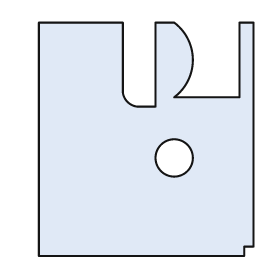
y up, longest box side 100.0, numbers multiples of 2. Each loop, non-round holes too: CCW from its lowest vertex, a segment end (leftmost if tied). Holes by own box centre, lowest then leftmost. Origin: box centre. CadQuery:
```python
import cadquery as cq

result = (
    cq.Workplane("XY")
    .moveTo(-46.0, -50.0)
    .lineTo(42.0, -50.0)
    .lineTo(42.0, -46.0)
    .lineTo(46.0, -46.0)
    .lineTo(46.0, 50.0)
    .lineTo(40.0, 50.0)
    .lineTo(40.0, 18.0)
    .lineTo(12.0, 18.0)
    .threePointArc((20.0, 34.0), (12.0, 50.0))
    .lineTo(4.0, 50.0)
    .lineTo(4.0, 14.0)
    .lineTo(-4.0, 14.0)
    .threePointArc((-8.0, 16.0), (-10.0, 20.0))
    .lineTo(-10.0, 50.0)
    .lineTo(-46.0, 50.0)
    .close()
    .moveTo(12.0, -8.0)
    .circle(8.0)
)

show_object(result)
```